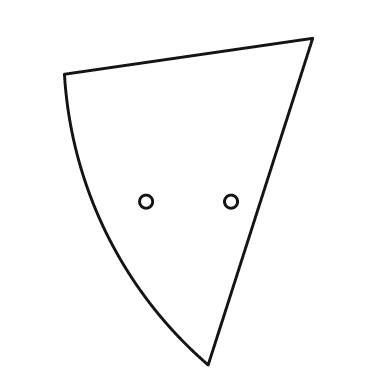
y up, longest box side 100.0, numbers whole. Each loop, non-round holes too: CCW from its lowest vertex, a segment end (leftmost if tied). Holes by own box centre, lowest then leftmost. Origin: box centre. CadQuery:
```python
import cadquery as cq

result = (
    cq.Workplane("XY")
    .moveTo(6.0, -50.0)
    .lineTo(38.0, 50.0)
    .lineTo(-38.0, 39.0)
    .threePointArc((-25.0, -10.0), (6.0, -50.0))
    .close()
    .moveTo(-13.0, 0.0)
    .circle(2.0)
    .moveTo(13.0, 0.0)
    .circle(2.0)
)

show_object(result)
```